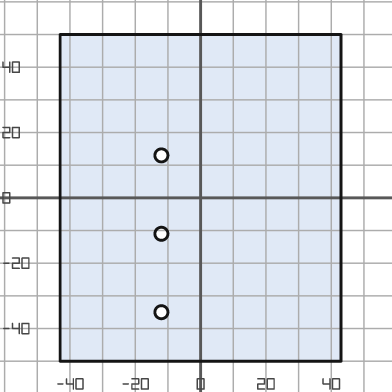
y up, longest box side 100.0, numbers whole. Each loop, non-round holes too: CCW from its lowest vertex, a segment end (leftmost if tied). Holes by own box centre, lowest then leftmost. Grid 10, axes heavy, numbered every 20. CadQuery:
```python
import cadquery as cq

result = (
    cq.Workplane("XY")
    .moveTo(-43.0, -50.0)
    .lineTo(43.0, -50.0)
    .lineTo(43.0, 50.0)
    .lineTo(-43.0, 50.0)
    .close()
    .moveTo(-12.0, -35.0)
    .circle(2.0)
    .moveTo(-12.0, -11.0)
    .circle(2.0)
    .moveTo(-12.0, 13.0)
    .circle(2.0)
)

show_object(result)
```